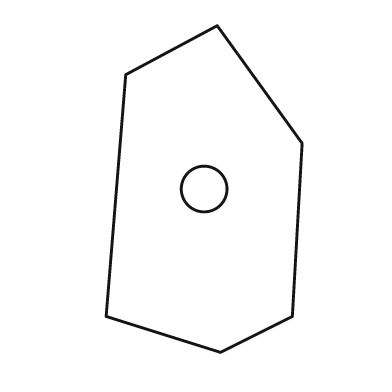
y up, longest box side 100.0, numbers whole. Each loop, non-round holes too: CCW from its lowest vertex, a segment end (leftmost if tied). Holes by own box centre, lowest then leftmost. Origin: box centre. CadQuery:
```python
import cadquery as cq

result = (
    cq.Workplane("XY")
    .moveTo(5.0, -50.0)
    .lineTo(27.0, -39.0)
    .lineTo(30.0, 14.0)
    .lineTo(4.0, 50.0)
    .lineTo(-24.0, 35.0)
    .lineTo(-30.0, -39.0)
    .close()
    .moveTo(0.0, 0.0)
    .circle(7.0)
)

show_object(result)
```